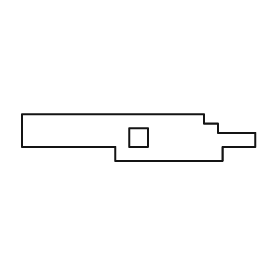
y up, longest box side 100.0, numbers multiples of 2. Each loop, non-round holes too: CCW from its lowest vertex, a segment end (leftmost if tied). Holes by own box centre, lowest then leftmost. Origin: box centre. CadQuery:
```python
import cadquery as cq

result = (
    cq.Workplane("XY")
    .moveTo(-10.0, -10.0)
    .lineTo(36.0, -10.0)
    .lineTo(36.0, -4.0)
    .lineTo(50.0, -4.0)
    .lineTo(50.0, 2.0)
    .lineTo(34.0, 2.0)
    .lineTo(34.0, 6.0)
    .lineTo(28.0, 6.0)
    .lineTo(28.0, 10.0)
    .lineTo(-50.0, 10.0)
    .lineTo(-50.0, -4.0)
    .lineTo(-10.0, -4.0)
    .close()
    .moveTo(-4.0, -4.0)
    .lineTo(4.0, -4.0)
    .lineTo(4.0, 4.0)
    .lineTo(-4.0, 4.0)
    .close()
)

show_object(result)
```